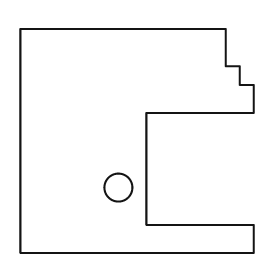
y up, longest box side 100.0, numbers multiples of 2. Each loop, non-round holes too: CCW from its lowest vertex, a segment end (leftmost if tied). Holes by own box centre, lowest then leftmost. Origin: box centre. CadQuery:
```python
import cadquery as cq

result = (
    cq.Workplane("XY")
    .moveTo(-50.0, -48.0)
    .lineTo(50.0, -48.0)
    .lineTo(50.0, -36.0)
    .lineTo(4.0, -36.0)
    .lineTo(4.0, 12.0)
    .lineTo(50.0, 12.0)
    .lineTo(50.0, 24.0)
    .lineTo(44.0, 24.0)
    .lineTo(44.0, 32.0)
    .lineTo(38.0, 32.0)
    .lineTo(38.0, 48.0)
    .lineTo(-50.0, 48.0)
    .close()
    .moveTo(-8.0, -20.0)
    .circle(6.0)
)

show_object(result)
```